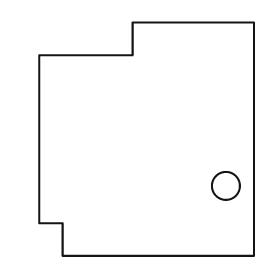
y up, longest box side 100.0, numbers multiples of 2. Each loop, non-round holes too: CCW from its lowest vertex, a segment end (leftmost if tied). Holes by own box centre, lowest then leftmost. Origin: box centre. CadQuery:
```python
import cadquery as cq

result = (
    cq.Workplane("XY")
    .moveTo(-36.0, -50.0)
    .lineTo(46.0, -50.0)
    .lineTo(46.0, 50.0)
    .lineTo(-6.0, 50.0)
    .lineTo(-6.0, 36.0)
    .lineTo(-46.0, 36.0)
    .lineTo(-46.0, -36.0)
    .lineTo(-36.0, -36.0)
    .close()
    .moveTo(34.0, -20.0)
    .circle(6.0)
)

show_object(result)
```